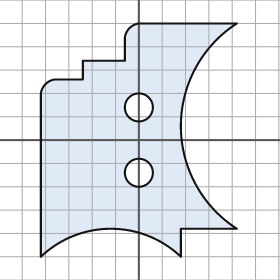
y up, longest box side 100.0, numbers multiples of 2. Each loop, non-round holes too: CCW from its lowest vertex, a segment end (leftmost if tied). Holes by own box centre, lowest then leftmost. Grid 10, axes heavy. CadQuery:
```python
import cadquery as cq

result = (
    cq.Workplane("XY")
    .moveTo(-42.0, -50.0)
    .threePointArc((-12.0, -38.0), (18.0, -50.0))
    .lineTo(18.0, -38.0)
    .lineTo(42.0, -38.0)
    .threePointArc((18.0, 6.0), (42.0, 50.0))
    .lineTo(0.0, 50.0)
    .threePointArc((-4.0, 48.0), (-6.0, 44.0))
    .lineTo(-6.0, 34.0)
    .lineTo(-24.0, 34.0)
    .lineTo(-24.0, 26.0)
    .lineTo(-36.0, 26.0)
    .threePointArc((-40.0, 24.0), (-42.0, 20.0))
    .close()
    .moveTo(0.0, -14.0)
    .circle(6.0)
    .moveTo(0.0, 14.0)
    .circle(6.0)
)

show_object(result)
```